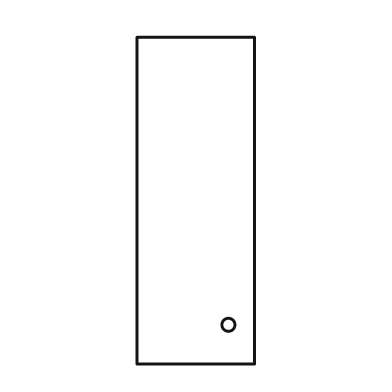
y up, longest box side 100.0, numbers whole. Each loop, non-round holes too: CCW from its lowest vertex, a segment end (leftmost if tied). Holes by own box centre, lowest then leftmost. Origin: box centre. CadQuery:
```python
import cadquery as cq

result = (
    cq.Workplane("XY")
    .moveTo(-18.0, -50.0)
    .lineTo(18.0, -50.0)
    .lineTo(18.0, 50.0)
    .lineTo(-18.0, 50.0)
    .close()
    .moveTo(10.0, -38.0)
    .circle(2.0)
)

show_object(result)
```